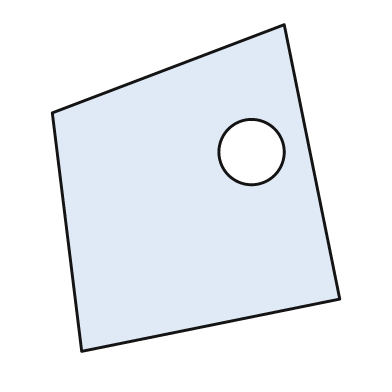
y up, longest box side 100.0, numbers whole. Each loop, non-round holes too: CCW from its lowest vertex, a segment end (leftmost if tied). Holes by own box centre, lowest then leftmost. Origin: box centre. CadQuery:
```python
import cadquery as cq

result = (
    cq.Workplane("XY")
    .moveTo(-35.0, -50.0)
    .lineTo(44.0, -34.0)
    .lineTo(27.0, 50.0)
    .lineTo(-44.0, 23.0)
    .close()
    .moveTo(17.0, 11.0)
    .circle(10.0)
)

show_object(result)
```